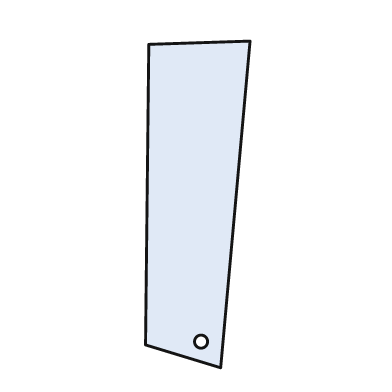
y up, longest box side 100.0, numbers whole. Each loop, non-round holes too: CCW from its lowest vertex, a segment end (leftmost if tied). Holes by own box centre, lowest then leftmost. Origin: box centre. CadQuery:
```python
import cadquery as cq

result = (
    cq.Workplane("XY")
    .moveTo(7.0, -50.0)
    .lineTo(16.0, 50.0)
    .lineTo(-15.0, 49.0)
    .lineTo(-16.0, -43.0)
    .close()
    .moveTo(1.0, -42.0)
    .circle(2.0)
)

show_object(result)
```